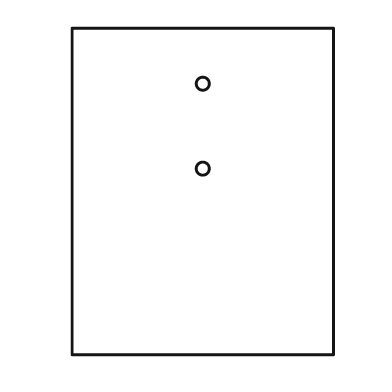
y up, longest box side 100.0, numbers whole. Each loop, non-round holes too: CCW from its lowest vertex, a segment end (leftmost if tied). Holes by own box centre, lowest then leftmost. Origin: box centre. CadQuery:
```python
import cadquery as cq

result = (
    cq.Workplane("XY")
    .moveTo(-40.0, -50.0)
    .lineTo(40.0, -50.0)
    .lineTo(40.0, 50.0)
    .lineTo(-40.0, 50.0)
    .close()
    .moveTo(0.0, 7.0)
    .circle(2.0)
    .moveTo(0.0, 33.0)
    .circle(2.0)
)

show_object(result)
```